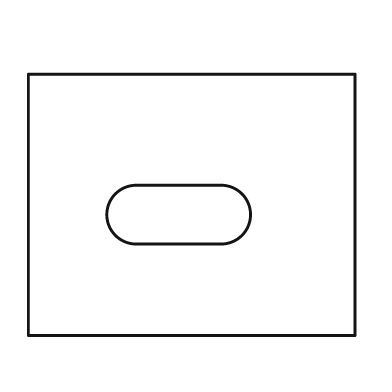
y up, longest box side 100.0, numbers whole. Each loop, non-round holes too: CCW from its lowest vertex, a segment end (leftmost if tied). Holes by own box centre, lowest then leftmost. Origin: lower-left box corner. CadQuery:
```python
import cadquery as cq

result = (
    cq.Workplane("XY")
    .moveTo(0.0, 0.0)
    .lineTo(100.0, 0.0)
    .lineTo(100.0, 80.0)
    .lineTo(0.0, 80.0)
    .close()
    .moveTo(33.0, 28.0)
    .lineTo(59.0, 28.0)
    .threePointArc((68.0, 37.0), (59.0, 46.0))
    .lineTo(33.0, 46.0)
    .threePointArc((24.0, 37.0), (33.0, 28.0))
    .close()
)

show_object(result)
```